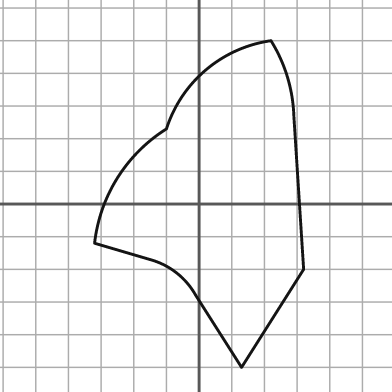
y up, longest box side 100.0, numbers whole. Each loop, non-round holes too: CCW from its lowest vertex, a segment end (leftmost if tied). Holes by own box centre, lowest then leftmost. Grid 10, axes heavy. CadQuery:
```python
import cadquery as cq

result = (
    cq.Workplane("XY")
    .moveTo(13.0, -50.0)
    .lineTo(32.0, -20.0)
    .lineTo(29.0, 27.0)
    .threePointArc((27.0, 39.0), (22.0, 50.0))
    .threePointArc((2.0, 41.0), (-10.0, 23.0))
    .threePointArc((-25.0, 8.0), (-32.0, -12.0))
    .lineTo(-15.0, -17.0)
    .threePointArc((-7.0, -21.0), (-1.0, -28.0))
    .close()
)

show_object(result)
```